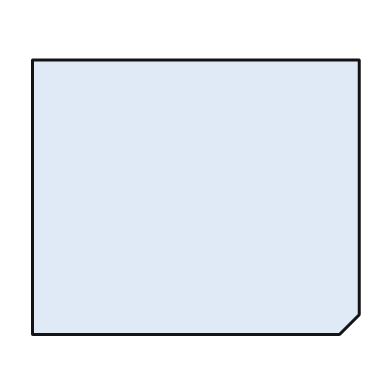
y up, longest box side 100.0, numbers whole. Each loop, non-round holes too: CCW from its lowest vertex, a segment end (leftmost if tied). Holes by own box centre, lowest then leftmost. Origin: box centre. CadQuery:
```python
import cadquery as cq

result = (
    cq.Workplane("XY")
    .moveTo(-50.0, -42.0)
    .lineTo(44.0, -42.0)
    .lineTo(50.0, -36.0)
    .lineTo(50.0, 42.0)
    .lineTo(-50.0, 42.0)
    .close()
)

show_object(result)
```